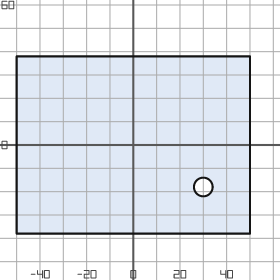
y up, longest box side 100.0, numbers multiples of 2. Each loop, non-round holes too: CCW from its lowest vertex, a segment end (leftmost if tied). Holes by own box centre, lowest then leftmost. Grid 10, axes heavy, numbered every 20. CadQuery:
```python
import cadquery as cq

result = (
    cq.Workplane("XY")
    .moveTo(-50.0, -38.0)
    .lineTo(50.0, -38.0)
    .lineTo(50.0, 38.0)
    .lineTo(-50.0, 38.0)
    .close()
    .moveTo(30.0, -18.0)
    .circle(4.0)
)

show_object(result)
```